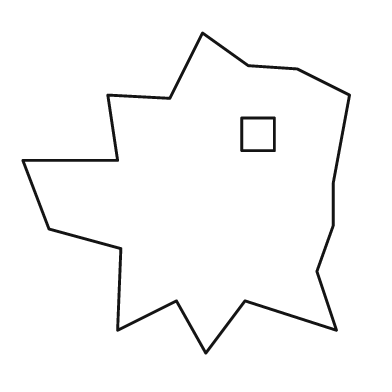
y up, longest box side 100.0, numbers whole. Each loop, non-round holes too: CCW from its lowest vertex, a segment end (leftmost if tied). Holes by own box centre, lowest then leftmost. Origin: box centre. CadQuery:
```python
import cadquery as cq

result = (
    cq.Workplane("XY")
    .moveTo(6.0, -49.0)
    .lineTo(18.0, -33.0)
    .lineTo(46.0, -42.0)
    .lineTo(40.0, -24.0)
    .lineTo(45.0, -10.0)
    .lineTo(45.0, 3.0)
    .lineTo(50.0, 30.0)
    .lineTo(34.0, 38.0)
    .lineTo(19.0, 39.0)
    .lineTo(5.0, 49.0)
    .lineTo(-5.0, 29.0)
    .lineTo(-24.0, 30.0)
    .lineTo(-21.0, 10.0)
    .lineTo(-50.0, 10.0)
    .lineTo(-42.0, -11.0)
    .lineTo(-20.0, -17.0)
    .lineTo(-21.0, -42.0)
    .lineTo(-3.0, -33.0)
    .close()
    .moveTo(17.0, 13.0)
    .lineTo(27.0, 13.0)
    .lineTo(27.0, 23.0)
    .lineTo(17.0, 23.0)
    .close()
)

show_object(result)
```